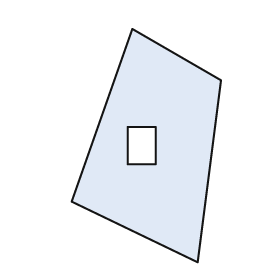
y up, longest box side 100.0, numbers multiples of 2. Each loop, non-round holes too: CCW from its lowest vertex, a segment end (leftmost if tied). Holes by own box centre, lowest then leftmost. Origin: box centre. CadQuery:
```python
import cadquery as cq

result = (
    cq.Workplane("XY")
    .moveTo(22.0, -50.0)
    .lineTo(32.0, 28.0)
    .lineTo(-6.0, 50.0)
    .lineTo(-32.0, -24.0)
    .close()
    .moveTo(-8.0, -8.0)
    .lineTo(4.0, -8.0)
    .lineTo(4.0, 8.0)
    .lineTo(-8.0, 8.0)
    .close()
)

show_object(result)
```